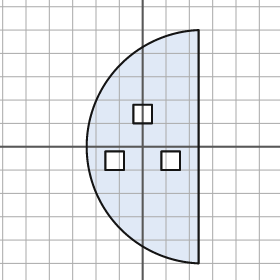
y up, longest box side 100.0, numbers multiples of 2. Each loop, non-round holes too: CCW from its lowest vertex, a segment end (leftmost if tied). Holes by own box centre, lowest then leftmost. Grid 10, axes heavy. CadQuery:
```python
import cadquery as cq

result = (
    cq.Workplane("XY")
    .moveTo(24.0, -50.0)
    .lineTo(24.0, 50.0)
    .threePointArc((-24.0, 0.0), (24.0, -50.0))
    .close()
    .moveTo(-16.0, -10.0)
    .lineTo(-8.0, -10.0)
    .lineTo(-8.0, -2.0)
    .lineTo(-16.0, -2.0)
    .close()
    .moveTo(8.0, -10.0)
    .lineTo(16.0, -10.0)
    .lineTo(16.0, -2.0)
    .lineTo(8.0, -2.0)
    .close()
    .moveTo(-4.0, 10.0)
    .lineTo(4.0, 10.0)
    .lineTo(4.0, 18.0)
    .lineTo(-4.0, 18.0)
    .close()
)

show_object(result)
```